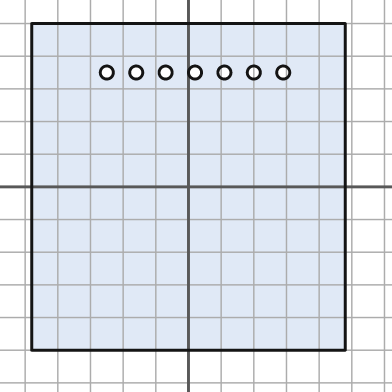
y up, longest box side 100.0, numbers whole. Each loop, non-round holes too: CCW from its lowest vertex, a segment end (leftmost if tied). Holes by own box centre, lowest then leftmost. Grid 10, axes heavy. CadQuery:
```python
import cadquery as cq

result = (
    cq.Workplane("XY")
    .moveTo(-48.0, -50.0)
    .lineTo(48.0, -50.0)
    .lineTo(48.0, 50.0)
    .lineTo(-48.0, 50.0)
    .close()
    .moveTo(-25.0, 35.0)
    .circle(2.0)
    .moveTo(-16.0, 35.0)
    .circle(2.0)
    .moveTo(-7.0, 35.0)
    .circle(2.0)
    .moveTo(2.0, 35.0)
    .circle(2.0)
    .moveTo(11.0, 35.0)
    .circle(2.0)
    .moveTo(20.0, 35.0)
    .circle(2.0)
    .moveTo(29.0, 35.0)
    .circle(2.0)
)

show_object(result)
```